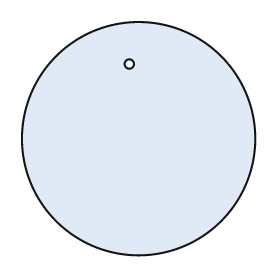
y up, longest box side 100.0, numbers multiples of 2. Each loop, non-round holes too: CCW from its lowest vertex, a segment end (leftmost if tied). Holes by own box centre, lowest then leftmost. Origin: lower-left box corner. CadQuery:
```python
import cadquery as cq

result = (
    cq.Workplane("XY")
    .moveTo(50.0, 50.0)
    .circle(50.0)
    .moveTo(46.0, 82.0)
    .circle(2.0)
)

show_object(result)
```